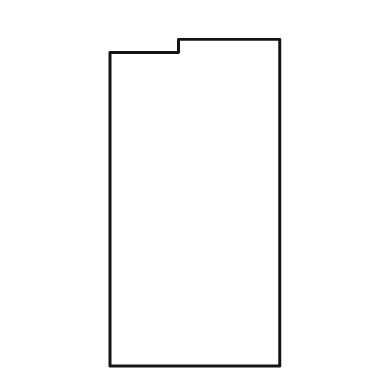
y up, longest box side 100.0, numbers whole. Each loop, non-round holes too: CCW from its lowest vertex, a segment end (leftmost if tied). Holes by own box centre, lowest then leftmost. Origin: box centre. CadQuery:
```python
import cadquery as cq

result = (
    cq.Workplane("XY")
    .moveTo(-26.0, -50.0)
    .lineTo(26.0, -50.0)
    .lineTo(26.0, 50.0)
    .lineTo(-5.0, 50.0)
    .lineTo(-5.0, 46.0)
    .lineTo(-26.0, 46.0)
    .close()
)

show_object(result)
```